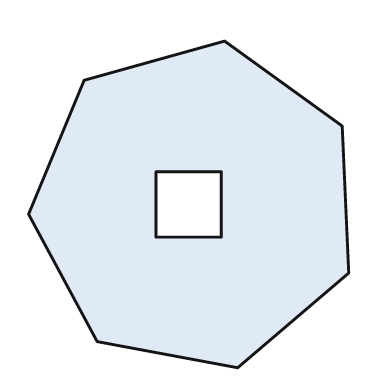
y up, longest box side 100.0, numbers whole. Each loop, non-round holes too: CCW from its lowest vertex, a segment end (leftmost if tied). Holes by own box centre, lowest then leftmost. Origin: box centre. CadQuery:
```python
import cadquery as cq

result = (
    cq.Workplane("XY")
    .moveTo(15.0, -50.0)
    .lineTo(49.0, -21.0)
    .lineTo(47.0, 24.0)
    .lineTo(11.0, 50.0)
    .lineTo(-32.0, 38.0)
    .lineTo(-49.0, -3.0)
    .lineTo(-28.0, -42.0)
    .close()
    .moveTo(-10.0, -10.0)
    .lineTo(10.0, -10.0)
    .lineTo(10.0, 10.0)
    .lineTo(-10.0, 10.0)
    .close()
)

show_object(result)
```